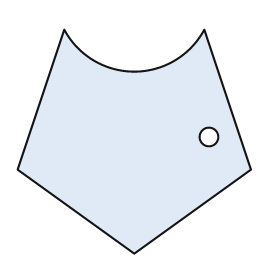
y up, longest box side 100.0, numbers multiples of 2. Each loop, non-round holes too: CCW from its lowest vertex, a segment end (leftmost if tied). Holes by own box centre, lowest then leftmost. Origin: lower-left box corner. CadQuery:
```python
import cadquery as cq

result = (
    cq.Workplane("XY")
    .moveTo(50.0, 0.0)
    .lineTo(100.0, 36.0)
    .lineTo(80.0, 96.0)
    .threePointArc((50.0, 78.0), (20.0, 96.0))
    .lineTo(0.0, 36.0)
    .close()
    .moveTo(82.0, 50.0)
    .circle(4.0)
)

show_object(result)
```